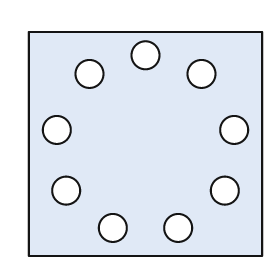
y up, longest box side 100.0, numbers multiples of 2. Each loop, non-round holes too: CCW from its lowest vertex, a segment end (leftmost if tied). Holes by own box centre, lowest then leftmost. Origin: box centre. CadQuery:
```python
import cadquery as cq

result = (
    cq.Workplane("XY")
    .moveTo(-50.0, -48.0)
    .lineTo(50.0, -48.0)
    .lineTo(50.0, 48.0)
    .lineTo(-50.0, 48.0)
    .close()
    .moveTo(-14.0, -36.0)
    .circle(6.0)
    .moveTo(14.0, -36.0)
    .circle(6.0)
    .moveTo(-34.0, -20.0)
    .circle(6.0)
    .moveTo(34.0, -20.0)
    .circle(6.0)
    .moveTo(-38.0, 6.0)
    .circle(6.0)
    .moveTo(38.0, 6.0)
    .circle(6.0)
    .moveTo(-24.0, 30.0)
    .circle(6.0)
    .moveTo(24.0, 30.0)
    .circle(6.0)
    .moveTo(0.0, 38.0)
    .circle(6.0)
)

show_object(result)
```